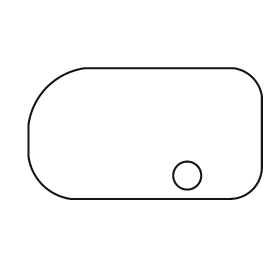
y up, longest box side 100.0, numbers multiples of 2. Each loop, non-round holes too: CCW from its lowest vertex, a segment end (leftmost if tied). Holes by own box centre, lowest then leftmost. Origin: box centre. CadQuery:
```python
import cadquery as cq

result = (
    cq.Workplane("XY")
    .moveTo(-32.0, -28.0)
    .lineTo(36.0, -28.0)
    .threePointArc((46.0, -24.0), (50.0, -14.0))
    .lineTo(50.0, 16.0)
    .threePointArc((46.0, 24.0), (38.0, 28.0))
    .lineTo(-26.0, 28.0)
    .threePointArc((-42.0, 20.0), (-50.0, 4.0))
    .lineTo(-50.0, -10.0)
    .threePointArc((-44.0, -22.0), (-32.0, -28.0))
    .close()
    .moveTo(18.0, -18.0)
    .circle(6.0)
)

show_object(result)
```